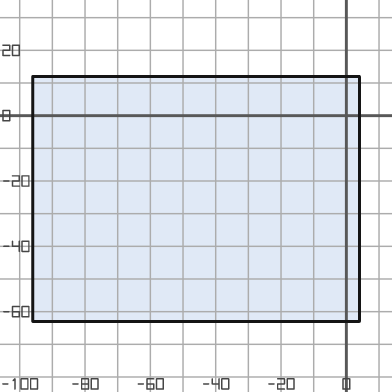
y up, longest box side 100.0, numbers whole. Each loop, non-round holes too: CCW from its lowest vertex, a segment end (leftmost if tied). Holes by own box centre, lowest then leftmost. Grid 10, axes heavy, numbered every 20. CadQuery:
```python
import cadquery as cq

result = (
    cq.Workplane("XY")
    .moveTo(-96.0, -63.0)
    .lineTo(4.0, -63.0)
    .lineTo(4.0, 12.0)
    .lineTo(-96.0, 12.0)
    .close()
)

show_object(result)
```